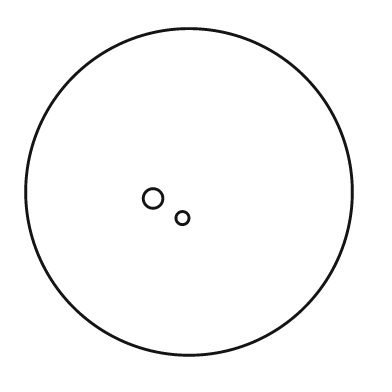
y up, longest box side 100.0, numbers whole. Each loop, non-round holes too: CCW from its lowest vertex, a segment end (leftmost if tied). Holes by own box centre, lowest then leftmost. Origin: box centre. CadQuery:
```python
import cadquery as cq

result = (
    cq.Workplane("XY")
    .moveTo(0.0, 0.0)
    .circle(50.0)
    .moveTo(-2.0, -8.0)
    .circle(2.0)
    .moveTo(-11.0, -2.0)
    .circle(3.0)
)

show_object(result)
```